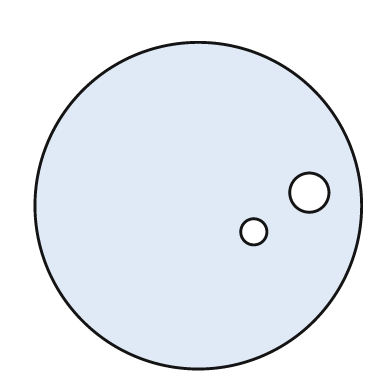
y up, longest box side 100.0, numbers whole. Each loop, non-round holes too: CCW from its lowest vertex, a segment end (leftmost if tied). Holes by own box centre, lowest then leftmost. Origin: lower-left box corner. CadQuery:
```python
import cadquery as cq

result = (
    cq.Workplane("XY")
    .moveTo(50.0, 50.0)
    .circle(50.0)
    .moveTo(67.0, 42.0)
    .circle(4.0)
    .moveTo(84.0, 54.0)
    .circle(6.0)
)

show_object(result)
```